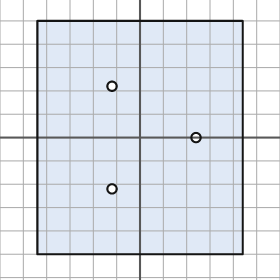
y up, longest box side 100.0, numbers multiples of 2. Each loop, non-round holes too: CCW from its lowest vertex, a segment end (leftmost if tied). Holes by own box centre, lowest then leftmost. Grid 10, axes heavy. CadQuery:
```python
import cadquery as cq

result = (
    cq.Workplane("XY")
    .moveTo(-44.0, -50.0)
    .lineTo(44.0, -50.0)
    .lineTo(44.0, 50.0)
    .lineTo(-44.0, 50.0)
    .close()
    .moveTo(-12.0, -22.0)
    .circle(2.0)
    .moveTo(24.0, 0.0)
    .circle(2.0)
    .moveTo(-12.0, 22.0)
    .circle(2.0)
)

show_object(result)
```